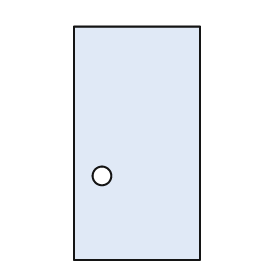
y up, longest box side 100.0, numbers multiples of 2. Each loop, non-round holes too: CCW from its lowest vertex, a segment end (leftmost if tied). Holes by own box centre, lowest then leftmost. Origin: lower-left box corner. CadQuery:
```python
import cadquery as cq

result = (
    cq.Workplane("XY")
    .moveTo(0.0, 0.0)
    .lineTo(54.0, 0.0)
    .lineTo(54.0, 100.0)
    .lineTo(0.0, 100.0)
    .close()
    .moveTo(12.0, 36.0)
    .circle(4.0)
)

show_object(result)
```